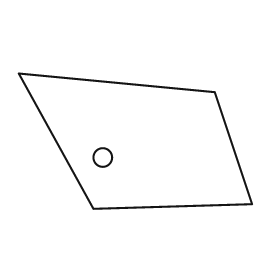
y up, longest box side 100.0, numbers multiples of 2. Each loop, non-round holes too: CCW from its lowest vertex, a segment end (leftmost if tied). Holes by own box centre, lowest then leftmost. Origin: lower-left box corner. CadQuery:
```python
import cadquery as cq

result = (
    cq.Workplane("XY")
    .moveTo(32.0, 0.0)
    .lineTo(100.0, 2.0)
    .lineTo(84.0, 50.0)
    .lineTo(0.0, 58.0)
    .close()
    .moveTo(36.0, 22.0)
    .circle(4.0)
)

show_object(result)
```